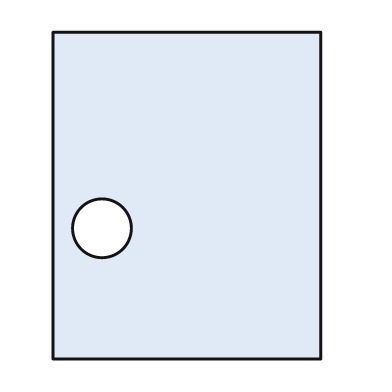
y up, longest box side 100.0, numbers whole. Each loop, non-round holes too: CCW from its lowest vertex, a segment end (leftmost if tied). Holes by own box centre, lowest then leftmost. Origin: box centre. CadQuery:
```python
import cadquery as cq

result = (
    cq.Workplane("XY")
    .moveTo(-41.0, -50.0)
    .lineTo(41.0, -50.0)
    .lineTo(41.0, 50.0)
    .lineTo(-41.0, 50.0)
    .close()
    .moveTo(-26.0, -10.0)
    .circle(9.0)
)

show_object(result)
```